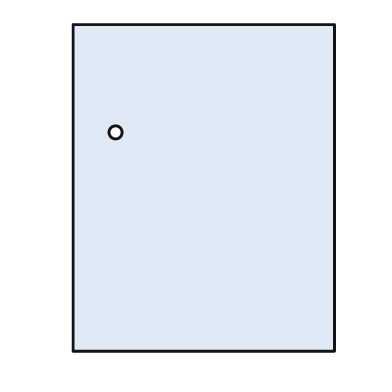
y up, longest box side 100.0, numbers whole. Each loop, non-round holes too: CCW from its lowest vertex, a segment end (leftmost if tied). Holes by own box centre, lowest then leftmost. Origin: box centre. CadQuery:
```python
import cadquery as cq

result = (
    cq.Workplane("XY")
    .moveTo(-40.0, -50.0)
    .lineTo(40.0, -50.0)
    .lineTo(40.0, 50.0)
    .lineTo(-40.0, 50.0)
    .close()
    .moveTo(-27.0, 17.0)
    .circle(2.0)
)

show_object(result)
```